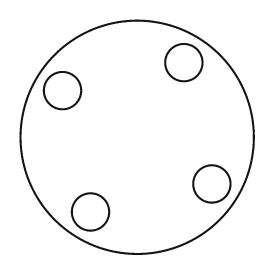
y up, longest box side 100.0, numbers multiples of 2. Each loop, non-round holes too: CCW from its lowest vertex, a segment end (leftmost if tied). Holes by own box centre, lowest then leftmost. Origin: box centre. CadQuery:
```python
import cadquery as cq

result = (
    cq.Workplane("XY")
    .moveTo(0.0, 0.0)
    .circle(50.0)
    .moveTo(-20.0, -32.0)
    .circle(8.0)
    .moveTo(32.0, -20.0)
    .circle(8.0)
    .moveTo(-32.0, 20.0)
    .circle(8.0)
    .moveTo(20.0, 32.0)
    .circle(8.0)
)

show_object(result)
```